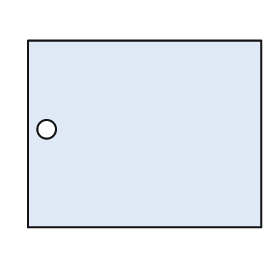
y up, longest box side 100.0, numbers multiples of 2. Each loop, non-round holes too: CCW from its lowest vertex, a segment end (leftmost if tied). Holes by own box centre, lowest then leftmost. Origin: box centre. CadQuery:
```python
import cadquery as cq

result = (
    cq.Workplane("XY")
    .moveTo(-50.0, -40.0)
    .lineTo(50.0, -40.0)
    .lineTo(50.0, 40.0)
    .lineTo(-50.0, 40.0)
    .close()
    .moveTo(-42.0, 2.0)
    .circle(4.0)
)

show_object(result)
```